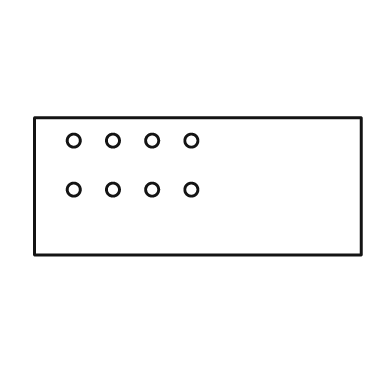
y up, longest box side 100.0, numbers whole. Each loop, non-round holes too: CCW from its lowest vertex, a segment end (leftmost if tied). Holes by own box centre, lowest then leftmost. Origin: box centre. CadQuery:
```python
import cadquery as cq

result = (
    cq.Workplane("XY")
    .moveTo(-50.0, -21.0)
    .lineTo(50.0, -21.0)
    .lineTo(50.0, 21.0)
    .lineTo(-50.0, 21.0)
    .close()
    .moveTo(-38.0, -1.0)
    .circle(2.0)
    .moveTo(-26.0, -1.0)
    .circle(2.0)
    .moveTo(-14.0, -1.0)
    .circle(2.0)
    .moveTo(-2.0, -1.0)
    .circle(2.0)
    .moveTo(-38.0, 14.0)
    .circle(2.0)
    .moveTo(-26.0, 14.0)
    .circle(2.0)
    .moveTo(-14.0, 14.0)
    .circle(2.0)
    .moveTo(-2.0, 14.0)
    .circle(2.0)
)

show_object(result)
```